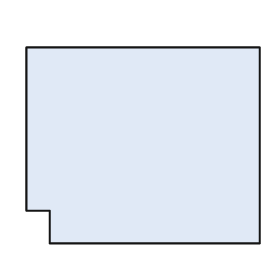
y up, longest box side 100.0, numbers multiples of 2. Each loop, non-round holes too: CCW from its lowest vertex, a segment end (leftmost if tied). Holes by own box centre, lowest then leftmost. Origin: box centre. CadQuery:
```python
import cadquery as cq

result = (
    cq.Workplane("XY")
    .moveTo(-40.0, -42.0)
    .lineTo(50.0, -42.0)
    .lineTo(50.0, 42.0)
    .lineTo(-50.0, 42.0)
    .lineTo(-50.0, -28.0)
    .lineTo(-40.0, -28.0)
    .close()
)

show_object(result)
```